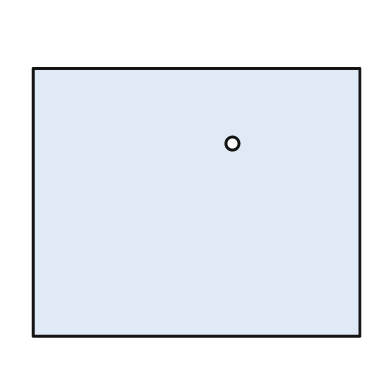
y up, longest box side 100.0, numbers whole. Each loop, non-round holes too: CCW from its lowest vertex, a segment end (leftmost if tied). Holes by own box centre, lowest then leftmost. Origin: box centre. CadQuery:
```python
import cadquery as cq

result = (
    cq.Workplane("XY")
    .moveTo(-50.0, -41.0)
    .lineTo(50.0, -41.0)
    .lineTo(50.0, 41.0)
    .lineTo(-50.0, 41.0)
    .close()
    .moveTo(11.0, 18.0)
    .circle(2.0)
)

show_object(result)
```